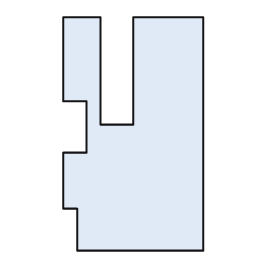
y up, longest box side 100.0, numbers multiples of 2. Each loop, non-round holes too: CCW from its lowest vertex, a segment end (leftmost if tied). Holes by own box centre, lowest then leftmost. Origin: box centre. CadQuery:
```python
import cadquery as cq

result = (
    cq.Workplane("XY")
    .moveTo(-24.0, -50.0)
    .lineTo(30.0, -50.0)
    .lineTo(30.0, 50.0)
    .lineTo(0.0, 50.0)
    .lineTo(0.0, 4.0)
    .lineTo(-14.0, 4.0)
    .lineTo(-14.0, 50.0)
    .lineTo(-30.0, 50.0)
    .lineTo(-30.0, 14.0)
    .lineTo(-20.0, 14.0)
    .lineTo(-20.0, -8.0)
    .lineTo(-30.0, -8.0)
    .lineTo(-30.0, -32.0)
    .lineTo(-24.0, -32.0)
    .close()
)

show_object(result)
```